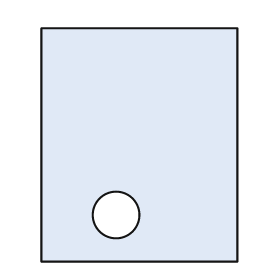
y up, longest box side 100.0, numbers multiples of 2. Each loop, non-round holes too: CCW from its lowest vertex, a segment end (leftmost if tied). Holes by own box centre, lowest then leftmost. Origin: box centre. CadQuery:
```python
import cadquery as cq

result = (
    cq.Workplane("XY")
    .moveTo(-42.0, -50.0)
    .lineTo(42.0, -50.0)
    .lineTo(42.0, 50.0)
    .lineTo(-42.0, 50.0)
    .close()
    .moveTo(-10.0, -30.0)
    .circle(10.0)
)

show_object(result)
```